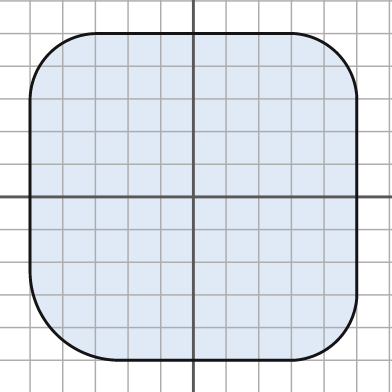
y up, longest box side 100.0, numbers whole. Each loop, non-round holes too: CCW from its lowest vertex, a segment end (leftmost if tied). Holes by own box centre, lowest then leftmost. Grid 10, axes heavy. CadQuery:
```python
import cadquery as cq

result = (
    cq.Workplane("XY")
    .moveTo(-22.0, -50.0)
    .lineTo(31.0, -50.0)
    .threePointArc((44.0, -44.0), (50.0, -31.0))
    .lineTo(50.0, 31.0)
    .threePointArc((44.0, 44.0), (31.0, 50.0))
    .lineTo(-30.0, 50.0)
    .threePointArc((-44.0, 44.0), (-50.0, 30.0))
    .lineTo(-50.0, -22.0)
    .threePointArc((-42.0, -42.0), (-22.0, -50.0))
    .close()
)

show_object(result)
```